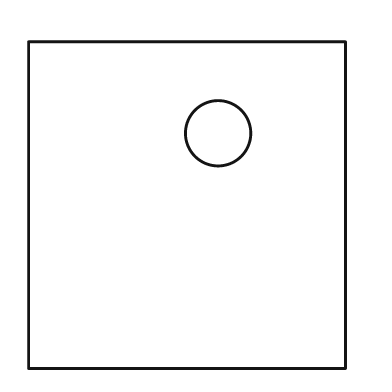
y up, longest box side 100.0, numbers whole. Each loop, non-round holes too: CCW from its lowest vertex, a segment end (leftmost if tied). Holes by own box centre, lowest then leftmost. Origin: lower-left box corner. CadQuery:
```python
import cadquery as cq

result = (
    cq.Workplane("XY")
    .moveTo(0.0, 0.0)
    .lineTo(97.0, 0.0)
    .lineTo(97.0, 100.0)
    .lineTo(0.0, 100.0)
    .close()
    .moveTo(58.0, 72.0)
    .circle(10.0)
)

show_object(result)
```